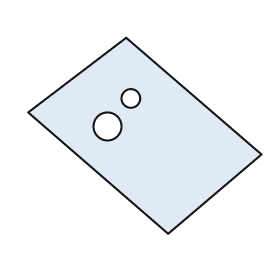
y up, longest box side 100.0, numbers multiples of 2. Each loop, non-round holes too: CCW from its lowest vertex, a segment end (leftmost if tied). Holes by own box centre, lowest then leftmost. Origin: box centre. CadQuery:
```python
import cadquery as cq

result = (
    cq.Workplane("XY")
    .moveTo(10.0, -42.0)
    .lineTo(50.0, -8.0)
    .lineTo(-8.0, 42.0)
    .lineTo(-50.0, 10.0)
    .close()
    .moveTo(-16.0, 4.0)
    .circle(6.0)
    .moveTo(-6.0, 16.0)
    .circle(4.0)
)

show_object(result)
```